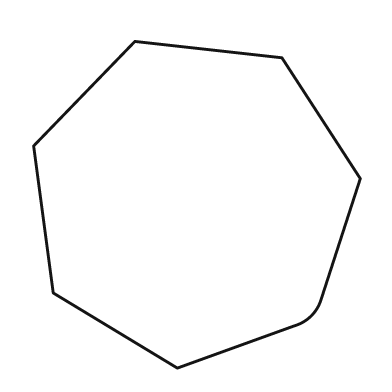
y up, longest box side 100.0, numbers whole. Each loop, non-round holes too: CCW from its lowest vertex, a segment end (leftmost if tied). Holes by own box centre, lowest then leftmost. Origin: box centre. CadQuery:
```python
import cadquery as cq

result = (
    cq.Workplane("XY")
    .moveTo(-6.0, -50.0)
    .lineTo(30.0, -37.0)
    .threePointArc((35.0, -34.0), (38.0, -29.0))
    .lineTo(50.0, 8.0)
    .lineTo(26.0, 45.0)
    .lineTo(-19.0, 50.0)
    .lineTo(-50.0, 18.0)
    .lineTo(-44.0, -27.0)
    .close()
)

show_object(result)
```